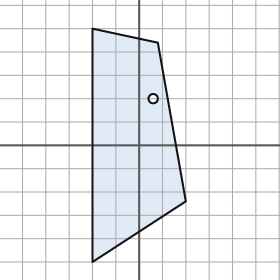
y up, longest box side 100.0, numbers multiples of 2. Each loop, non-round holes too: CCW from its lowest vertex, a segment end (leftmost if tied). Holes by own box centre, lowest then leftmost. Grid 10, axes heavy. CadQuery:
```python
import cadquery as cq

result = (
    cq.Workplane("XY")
    .moveTo(-20.0, -50.0)
    .lineTo(20.0, -24.0)
    .lineTo(8.0, 44.0)
    .lineTo(-20.0, 50.0)
    .close()
    .moveTo(6.0, 20.0)
    .circle(2.0)
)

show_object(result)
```